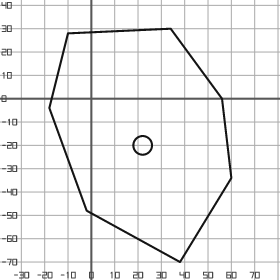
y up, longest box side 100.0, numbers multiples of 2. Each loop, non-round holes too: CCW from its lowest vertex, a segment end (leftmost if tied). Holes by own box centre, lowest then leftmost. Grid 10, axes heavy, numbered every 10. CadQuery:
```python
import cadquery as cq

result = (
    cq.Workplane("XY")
    .moveTo(38.0, -70.0)
    .lineTo(60.0, -34.0)
    .lineTo(56.0, 0.0)
    .lineTo(34.0, 30.0)
    .lineTo(-10.0, 28.0)
    .lineTo(-18.0, -4.0)
    .lineTo(-2.0, -48.0)
    .close()
    .moveTo(22.0, -20.0)
    .circle(4.0)
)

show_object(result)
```